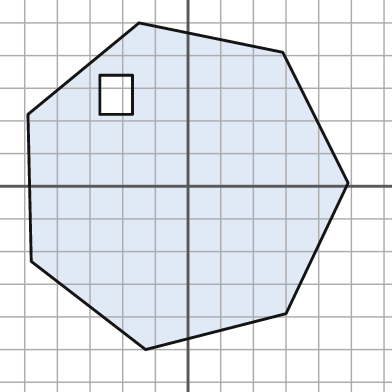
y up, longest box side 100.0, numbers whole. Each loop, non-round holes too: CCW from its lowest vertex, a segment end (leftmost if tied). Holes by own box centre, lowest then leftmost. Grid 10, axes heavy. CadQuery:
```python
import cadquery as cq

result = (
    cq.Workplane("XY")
    .moveTo(-13.0, -50.0)
    .lineTo(30.0, -39.0)
    .lineTo(49.0, 1.0)
    .lineTo(29.0, 41.0)
    .lineTo(-15.0, 50.0)
    .lineTo(-49.0, 22.0)
    .lineTo(-48.0, -23.0)
    .close()
    .moveTo(-27.0, 22.0)
    .lineTo(-17.0, 22.0)
    .lineTo(-17.0, 34.0)
    .lineTo(-27.0, 34.0)
    .close()
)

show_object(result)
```